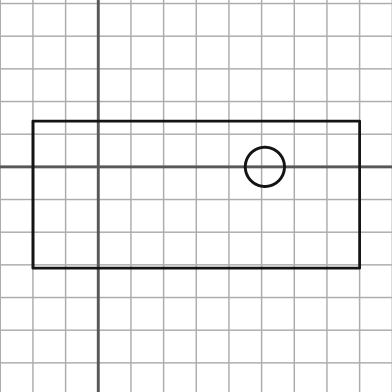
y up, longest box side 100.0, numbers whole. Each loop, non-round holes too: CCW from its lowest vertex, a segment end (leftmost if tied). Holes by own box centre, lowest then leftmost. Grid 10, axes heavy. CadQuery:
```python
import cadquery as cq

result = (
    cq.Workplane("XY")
    .moveTo(-20.0, -31.0)
    .lineTo(80.0, -31.0)
    .lineTo(80.0, 14.0)
    .lineTo(-20.0, 14.0)
    .close()
    .moveTo(51.0, 0.0)
    .circle(6.0)
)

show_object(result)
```